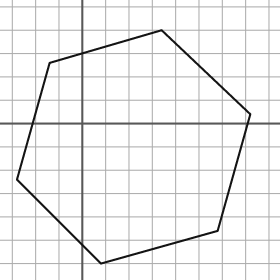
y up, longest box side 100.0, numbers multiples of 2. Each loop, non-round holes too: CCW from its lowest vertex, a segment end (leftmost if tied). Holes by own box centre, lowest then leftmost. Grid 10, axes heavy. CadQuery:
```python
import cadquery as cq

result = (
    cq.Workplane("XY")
    .moveTo(8.0, -60.0)
    .lineTo(58.0, -46.0)
    .lineTo(72.0, 4.0)
    .lineTo(34.0, 40.0)
    .lineTo(-14.0, 26.0)
    .lineTo(-28.0, -24.0)
    .close()
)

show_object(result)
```